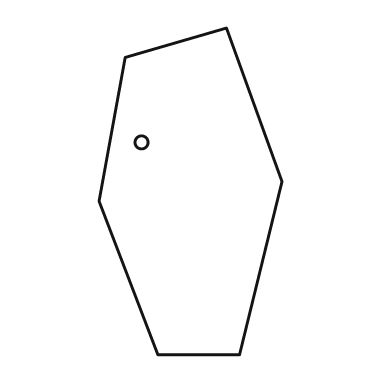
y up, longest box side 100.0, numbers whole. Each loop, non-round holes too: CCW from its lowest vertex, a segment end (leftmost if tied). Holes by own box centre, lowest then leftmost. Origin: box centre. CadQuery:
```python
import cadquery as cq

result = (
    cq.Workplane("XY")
    .moveTo(-10.0, -50.0)
    .lineTo(15.0, -50.0)
    .lineTo(28.0, 3.0)
    .lineTo(11.0, 50.0)
    .lineTo(-20.0, 41.0)
    .lineTo(-28.0, -3.0)
    .close()
    .moveTo(-15.0, 15.0)
    .circle(2.0)
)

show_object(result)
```